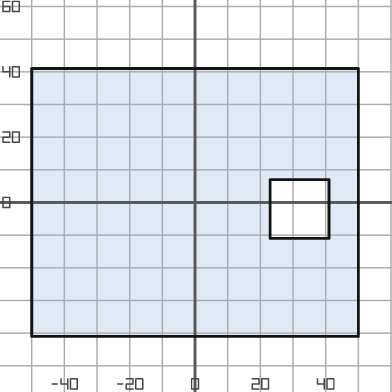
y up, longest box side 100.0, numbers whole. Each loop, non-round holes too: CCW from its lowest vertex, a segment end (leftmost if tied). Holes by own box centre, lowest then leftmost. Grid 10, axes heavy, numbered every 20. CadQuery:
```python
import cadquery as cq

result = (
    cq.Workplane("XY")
    .moveTo(-50.0, -41.0)
    .lineTo(50.0, -41.0)
    .lineTo(50.0, 41.0)
    .lineTo(-50.0, 41.0)
    .close()
    .moveTo(23.0, -11.0)
    .lineTo(41.0, -11.0)
    .lineTo(41.0, 7.0)
    .lineTo(23.0, 7.0)
    .close()
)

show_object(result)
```